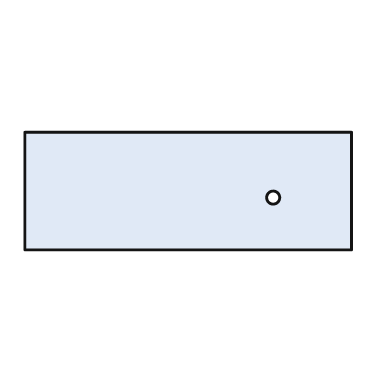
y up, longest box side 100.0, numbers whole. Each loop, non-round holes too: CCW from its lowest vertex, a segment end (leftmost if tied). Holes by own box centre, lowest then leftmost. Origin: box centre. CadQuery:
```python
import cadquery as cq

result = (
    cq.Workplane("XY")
    .moveTo(-50.0, -18.0)
    .lineTo(50.0, -18.0)
    .lineTo(50.0, 18.0)
    .lineTo(-50.0, 18.0)
    .close()
    .moveTo(26.0, -2.0)
    .circle(2.0)
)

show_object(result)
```